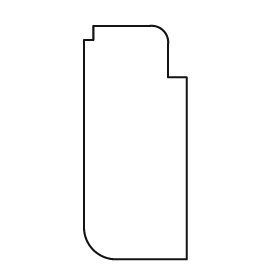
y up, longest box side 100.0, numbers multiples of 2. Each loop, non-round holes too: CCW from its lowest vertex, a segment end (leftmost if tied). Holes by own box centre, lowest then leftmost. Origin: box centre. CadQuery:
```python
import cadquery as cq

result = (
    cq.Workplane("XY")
    .moveTo(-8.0, -50.0)
    .lineTo(22.0, -50.0)
    .lineTo(22.0, 28.0)
    .lineTo(14.0, 28.0)
    .lineTo(14.0, 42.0)
    .threePointArc((12.0, 48.0), (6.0, 50.0))
    .lineTo(-18.0, 50.0)
    .lineTo(-18.0, 44.0)
    .lineTo(-22.0, 44.0)
    .lineTo(-22.0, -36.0)
    .threePointArc((-18.0, -46.0), (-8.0, -50.0))
    .close()
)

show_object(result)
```